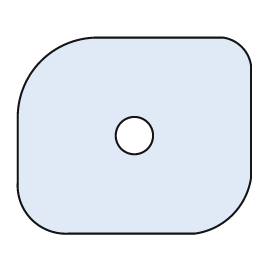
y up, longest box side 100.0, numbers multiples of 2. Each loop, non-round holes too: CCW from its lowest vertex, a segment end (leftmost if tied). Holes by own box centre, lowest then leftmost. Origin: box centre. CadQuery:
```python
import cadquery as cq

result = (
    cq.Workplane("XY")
    .moveTo(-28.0, -42.0)
    .lineTo(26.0, -42.0)
    .threePointArc((42.0, -34.0), (50.0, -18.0))
    .lineTo(50.0, 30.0)
    .threePointArc((46.0, 38.0), (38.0, 42.0))
    .lineTo(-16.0, 42.0)
    .threePointArc((-40.0, 32.0), (-50.0, 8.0))
    .lineTo(-50.0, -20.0)
    .threePointArc((-44.0, -36.0), (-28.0, -42.0))
    .close()
    .moveTo(0.0, 0.0)
    .circle(8.0)
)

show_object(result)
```